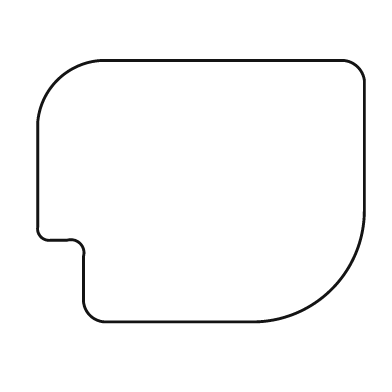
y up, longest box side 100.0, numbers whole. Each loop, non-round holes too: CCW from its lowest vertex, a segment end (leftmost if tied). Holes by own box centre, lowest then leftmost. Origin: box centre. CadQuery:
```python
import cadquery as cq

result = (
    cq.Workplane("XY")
    .moveTo(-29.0, -40.0)
    .lineTo(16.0, -40.0)
    .threePointArc((40.0, -30.0), (50.0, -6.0))
    .lineTo(50.0, 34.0)
    .threePointArc((48.0, 38.0), (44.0, 40.0))
    .lineTo(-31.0, 40.0)
    .threePointArc((-44.0, 34.0), (-50.0, 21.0))
    .lineTo(-50.0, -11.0)
    .threePointArc((-49.0, -14.0), (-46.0, -15.0))
    .lineTo(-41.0, -15.0)
    .threePointArc((-37.0, -16.0), (-36.0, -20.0))
    .lineTo(-36.0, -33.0)
    .threePointArc((-34.0, -38.0), (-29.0, -40.0))
    .close()
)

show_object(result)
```